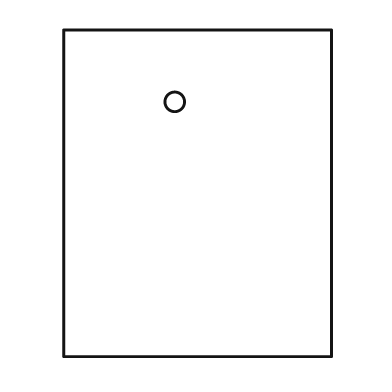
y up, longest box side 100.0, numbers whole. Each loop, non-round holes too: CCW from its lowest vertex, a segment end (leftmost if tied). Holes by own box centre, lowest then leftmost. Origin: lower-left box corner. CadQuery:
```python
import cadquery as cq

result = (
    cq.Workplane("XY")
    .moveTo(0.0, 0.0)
    .lineTo(82.0, 0.0)
    .lineTo(82.0, 100.0)
    .lineTo(0.0, 100.0)
    .close()
    .moveTo(34.0, 78.0)
    .circle(3.0)
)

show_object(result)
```